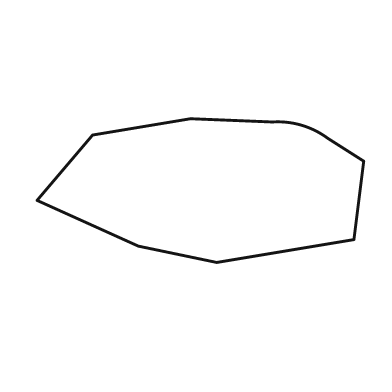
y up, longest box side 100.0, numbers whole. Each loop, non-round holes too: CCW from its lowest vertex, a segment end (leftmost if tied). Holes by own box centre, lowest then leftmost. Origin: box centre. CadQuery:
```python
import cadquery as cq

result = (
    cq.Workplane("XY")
    .moveTo(5.0, -22.0)
    .lineTo(47.0, -15.0)
    .lineTo(50.0, 9.0)
    .lineTo(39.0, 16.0)
    .threePointArc((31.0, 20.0), (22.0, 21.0))
    .lineTo(-3.0, 22.0)
    .lineTo(-33.0, 17.0)
    .lineTo(-50.0, -3.0)
    .lineTo(-19.0, -17.0)
    .close()
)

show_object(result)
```